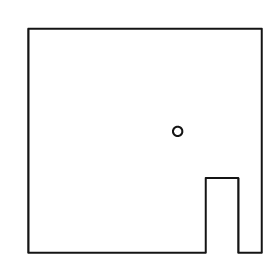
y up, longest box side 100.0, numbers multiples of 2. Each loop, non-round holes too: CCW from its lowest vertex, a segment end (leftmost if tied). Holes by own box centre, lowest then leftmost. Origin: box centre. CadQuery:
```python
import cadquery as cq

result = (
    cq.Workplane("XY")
    .moveTo(-50.0, -48.0)
    .lineTo(26.0, -48.0)
    .lineTo(26.0, -16.0)
    .lineTo(40.0, -16.0)
    .lineTo(40.0, -48.0)
    .lineTo(50.0, -48.0)
    .lineTo(50.0, 48.0)
    .lineTo(-50.0, 48.0)
    .close()
    .moveTo(14.0, 4.0)
    .circle(2.0)
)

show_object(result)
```